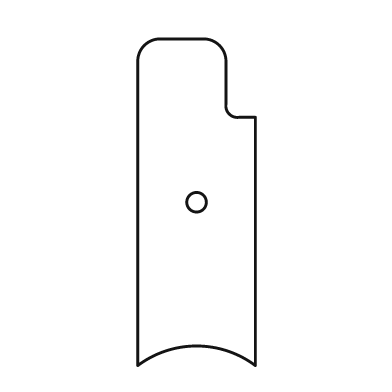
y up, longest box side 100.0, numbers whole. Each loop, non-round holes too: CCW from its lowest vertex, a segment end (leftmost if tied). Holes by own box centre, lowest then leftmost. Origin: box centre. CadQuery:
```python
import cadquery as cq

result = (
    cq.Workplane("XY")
    .moveTo(-18.0, -50.0)
    .threePointArc((0.0, -44.0), (18.0, -50.0))
    .lineTo(18.0, 26.0)
    .lineTo(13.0, 26.0)
    .threePointArc((10.0, 27.0), (9.0, 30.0))
    .lineTo(9.0, 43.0)
    .threePointArc((7.0, 48.0), (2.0, 50.0))
    .lineTo(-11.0, 50.0)
    .threePointArc((-16.0, 48.0), (-18.0, 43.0))
    .close()
    .moveTo(0.0, 0.0)
    .circle(3.0)
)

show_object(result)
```